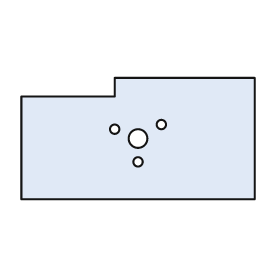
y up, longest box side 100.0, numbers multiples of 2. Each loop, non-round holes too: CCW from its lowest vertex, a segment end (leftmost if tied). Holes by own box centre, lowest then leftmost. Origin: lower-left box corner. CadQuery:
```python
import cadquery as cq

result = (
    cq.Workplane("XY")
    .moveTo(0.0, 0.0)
    .lineTo(100.0, 0.0)
    .lineTo(100.0, 52.0)
    .lineTo(40.0, 52.0)
    .lineTo(40.0, 44.0)
    .lineTo(0.0, 44.0)
    .close()
    .moveTo(50.0, 16.0)
    .circle(2.0)
    .moveTo(50.0, 26.0)
    .circle(4.0)
    .moveTo(40.0, 30.0)
    .circle(2.0)
    .moveTo(60.0, 32.0)
    .circle(2.0)
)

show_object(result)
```